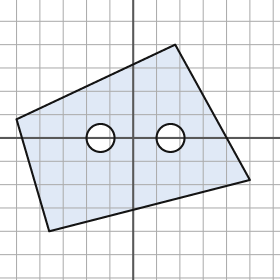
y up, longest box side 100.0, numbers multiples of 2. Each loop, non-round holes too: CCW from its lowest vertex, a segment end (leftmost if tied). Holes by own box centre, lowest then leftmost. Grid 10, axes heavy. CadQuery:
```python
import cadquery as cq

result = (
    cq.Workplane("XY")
    .moveTo(-36.0, -40.0)
    .lineTo(50.0, -18.0)
    .lineTo(18.0, 40.0)
    .lineTo(-50.0, 8.0)
    .close()
    .moveTo(-14.0, 0.0)
    .circle(6.0)
    .moveTo(16.0, 0.0)
    .circle(6.0)
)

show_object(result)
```